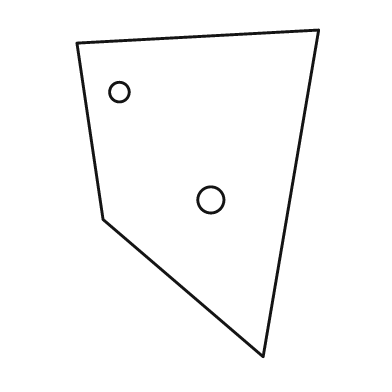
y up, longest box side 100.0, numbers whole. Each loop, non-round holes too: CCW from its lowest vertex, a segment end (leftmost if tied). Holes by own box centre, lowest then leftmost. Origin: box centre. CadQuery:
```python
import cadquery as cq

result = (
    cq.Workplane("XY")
    .moveTo(20.0, -50.0)
    .lineTo(37.0, 50.0)
    .lineTo(-37.0, 46.0)
    .lineTo(-29.0, -8.0)
    .close()
    .moveTo(4.0, -2.0)
    .circle(4.0)
    .moveTo(-24.0, 31.0)
    .circle(3.0)
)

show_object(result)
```